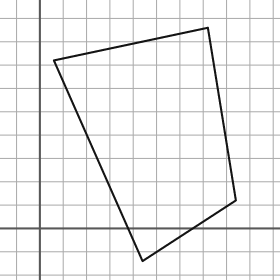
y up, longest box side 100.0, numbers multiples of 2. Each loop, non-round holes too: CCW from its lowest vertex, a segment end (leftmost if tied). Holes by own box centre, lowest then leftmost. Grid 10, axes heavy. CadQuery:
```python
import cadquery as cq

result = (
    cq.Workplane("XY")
    .moveTo(44.0, -14.0)
    .lineTo(84.0, 12.0)
    .lineTo(72.0, 86.0)
    .lineTo(6.0, 72.0)
    .close()
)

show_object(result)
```